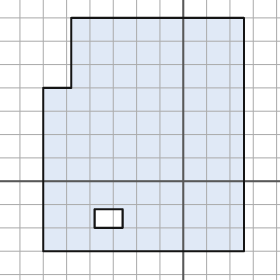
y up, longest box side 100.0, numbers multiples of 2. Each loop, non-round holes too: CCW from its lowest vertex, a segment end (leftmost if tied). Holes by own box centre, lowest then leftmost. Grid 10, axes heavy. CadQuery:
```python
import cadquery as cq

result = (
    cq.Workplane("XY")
    .moveTo(-60.0, -30.0)
    .lineTo(26.0, -30.0)
    .lineTo(26.0, 70.0)
    .lineTo(-48.0, 70.0)
    .lineTo(-48.0, 40.0)
    .lineTo(-60.0, 40.0)
    .close()
    .moveTo(-38.0, -20.0)
    .lineTo(-26.0, -20.0)
    .lineTo(-26.0, -12.0)
    .lineTo(-38.0, -12.0)
    .close()
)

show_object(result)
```